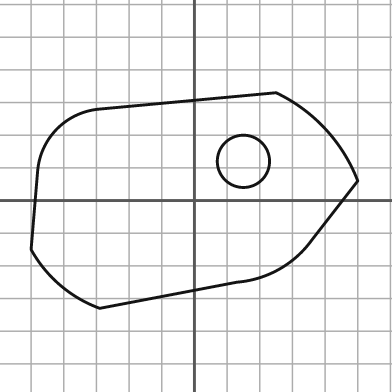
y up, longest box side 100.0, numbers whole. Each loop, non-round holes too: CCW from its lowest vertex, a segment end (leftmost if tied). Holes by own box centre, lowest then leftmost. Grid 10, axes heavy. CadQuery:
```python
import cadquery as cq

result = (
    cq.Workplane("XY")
    .moveTo(-29.0, -33.0)
    .lineTo(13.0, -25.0)
    .threePointArc((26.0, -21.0), (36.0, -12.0))
    .lineTo(50.0, 6.0)
    .threePointArc((40.0, 22.0), (25.0, 33.0))
    .lineTo(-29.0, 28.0)
    .threePointArc((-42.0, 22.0), (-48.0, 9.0))
    .lineTo(-50.0, -15.0)
    .threePointArc((-41.0, -26.0), (-29.0, -33.0))
    .close()
    .moveTo(15.0, 12.0)
    .circle(8.0)
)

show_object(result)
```